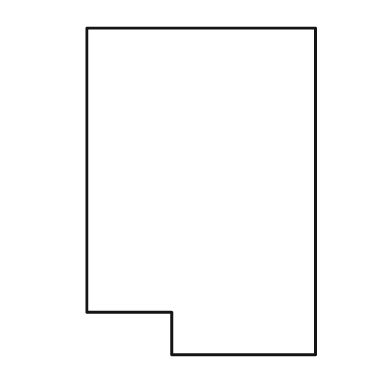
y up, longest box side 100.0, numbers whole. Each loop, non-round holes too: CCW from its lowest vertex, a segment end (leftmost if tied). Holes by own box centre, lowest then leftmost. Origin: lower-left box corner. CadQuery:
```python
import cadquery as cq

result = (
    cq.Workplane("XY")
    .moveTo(26.0, 0.0)
    .lineTo(70.0, 0.0)
    .lineTo(70.0, 100.0)
    .lineTo(0.0, 100.0)
    .lineTo(0.0, 13.0)
    .lineTo(26.0, 13.0)
    .close()
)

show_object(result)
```